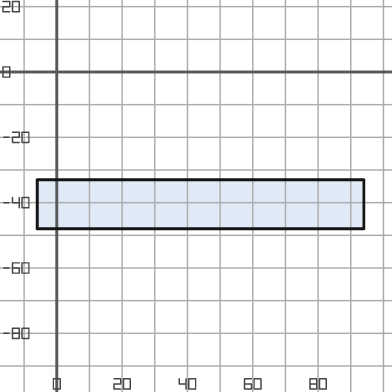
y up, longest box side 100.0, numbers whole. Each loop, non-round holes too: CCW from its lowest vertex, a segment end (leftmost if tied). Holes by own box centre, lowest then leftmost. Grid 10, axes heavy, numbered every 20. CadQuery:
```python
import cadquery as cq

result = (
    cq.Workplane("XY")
    .moveTo(-6.0, -48.0)
    .lineTo(94.0, -48.0)
    .lineTo(94.0, -33.0)
    .lineTo(-6.0, -33.0)
    .close()
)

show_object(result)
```